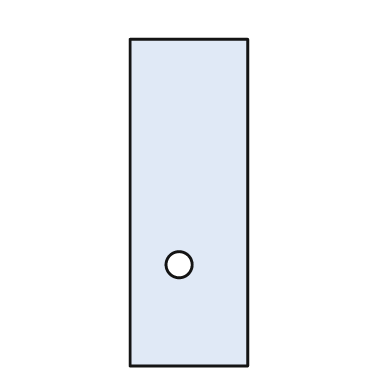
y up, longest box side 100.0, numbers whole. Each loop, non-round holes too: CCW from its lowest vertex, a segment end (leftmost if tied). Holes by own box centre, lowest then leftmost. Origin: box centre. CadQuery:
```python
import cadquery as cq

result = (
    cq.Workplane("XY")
    .moveTo(-18.0, -50.0)
    .lineTo(18.0, -50.0)
    .lineTo(18.0, 50.0)
    .lineTo(-18.0, 50.0)
    .close()
    .moveTo(-3.0, -19.0)
    .circle(4.0)
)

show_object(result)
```